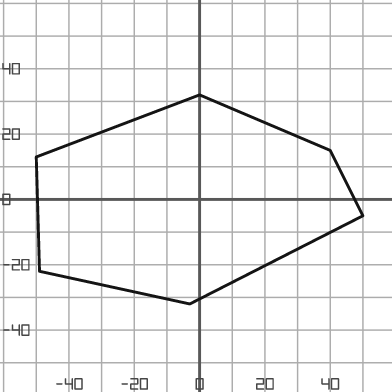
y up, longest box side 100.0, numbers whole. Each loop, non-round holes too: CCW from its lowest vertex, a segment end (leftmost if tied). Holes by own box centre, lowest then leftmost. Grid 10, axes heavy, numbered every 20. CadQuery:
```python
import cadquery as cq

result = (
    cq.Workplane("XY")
    .moveTo(-3.0, -32.0)
    .lineTo(50.0, -5.0)
    .lineTo(40.0, 15.0)
    .lineTo(0.0, 32.0)
    .lineTo(-50.0, 13.0)
    .lineTo(-49.0, -22.0)
    .close()
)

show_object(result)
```